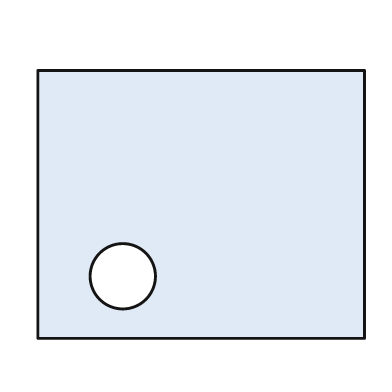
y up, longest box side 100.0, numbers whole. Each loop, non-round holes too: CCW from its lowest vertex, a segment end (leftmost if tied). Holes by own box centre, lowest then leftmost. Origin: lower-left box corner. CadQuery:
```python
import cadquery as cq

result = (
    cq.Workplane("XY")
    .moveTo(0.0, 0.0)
    .lineTo(100.0, 0.0)
    .lineTo(100.0, 82.0)
    .lineTo(0.0, 82.0)
    .close()
    .moveTo(26.0, 19.0)
    .circle(10.0)
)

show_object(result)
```